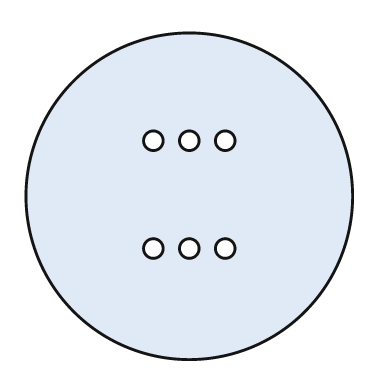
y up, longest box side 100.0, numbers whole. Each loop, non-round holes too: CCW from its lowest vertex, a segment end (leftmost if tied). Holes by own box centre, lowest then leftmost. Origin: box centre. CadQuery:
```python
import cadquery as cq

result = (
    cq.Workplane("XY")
    .moveTo(0.0, 0.0)
    .circle(50.0)
    .moveTo(-11.0, -16.0)
    .circle(3.0)
    .moveTo(0.0, -16.0)
    .circle(3.0)
    .moveTo(11.0, -16.0)
    .circle(3.0)
    .moveTo(-11.0, 17.0)
    .circle(3.0)
    .moveTo(0.0, 17.0)
    .circle(3.0)
    .moveTo(11.0, 17.0)
    .circle(3.0)
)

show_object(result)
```